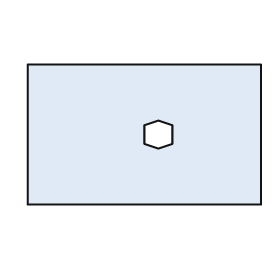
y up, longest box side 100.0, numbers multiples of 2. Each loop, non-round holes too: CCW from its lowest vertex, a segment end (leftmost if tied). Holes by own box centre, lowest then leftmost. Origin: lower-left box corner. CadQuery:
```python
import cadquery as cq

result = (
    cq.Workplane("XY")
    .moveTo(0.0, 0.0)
    .lineTo(100.0, 0.0)
    .lineTo(100.0, 60.0)
    .lineTo(0.0, 60.0)
    .close()
    .moveTo(56.0, 24.0)
    .lineTo(62.0, 26.0)
    .lineTo(62.0, 34.0)
    .lineTo(56.0, 36.0)
    .lineTo(50.0, 34.0)
    .lineTo(50.0, 26.0)
    .close()
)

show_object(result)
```